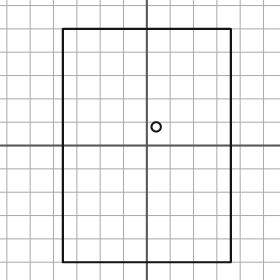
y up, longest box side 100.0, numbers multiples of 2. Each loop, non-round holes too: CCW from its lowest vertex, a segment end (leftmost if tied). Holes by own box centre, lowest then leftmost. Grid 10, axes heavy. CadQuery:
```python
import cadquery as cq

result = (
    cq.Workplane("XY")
    .moveTo(-36.0, -50.0)
    .lineTo(36.0, -50.0)
    .lineTo(36.0, 50.0)
    .lineTo(-36.0, 50.0)
    .close()
    .moveTo(4.0, 8.0)
    .circle(2.0)
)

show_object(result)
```